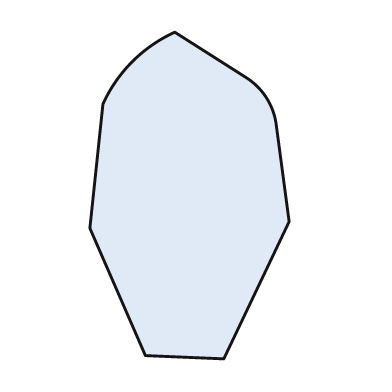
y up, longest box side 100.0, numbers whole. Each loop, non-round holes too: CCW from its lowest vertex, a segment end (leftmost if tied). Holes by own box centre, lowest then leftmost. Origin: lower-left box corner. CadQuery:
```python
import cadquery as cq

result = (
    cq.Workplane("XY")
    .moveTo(41.0, 0.0)
    .lineTo(61.0, 42.0)
    .lineTo(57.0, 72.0)
    .threePointArc((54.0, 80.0), (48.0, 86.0))
    .lineTo(26.0, 100.0)
    .threePointArc((13.0, 91.0), (4.0, 78.0))
    .lineTo(0.0, 40.0)
    .lineTo(17.0, 1.0)
    .close()
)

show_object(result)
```